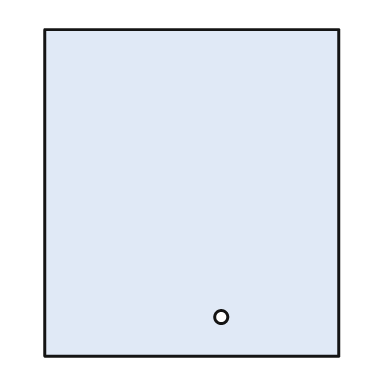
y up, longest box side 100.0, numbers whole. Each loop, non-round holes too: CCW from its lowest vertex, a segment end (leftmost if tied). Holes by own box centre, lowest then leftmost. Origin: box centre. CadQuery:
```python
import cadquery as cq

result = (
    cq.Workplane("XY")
    .moveTo(-45.0, -50.0)
    .lineTo(45.0, -50.0)
    .lineTo(45.0, 50.0)
    .lineTo(-45.0, 50.0)
    .close()
    .moveTo(9.0, -38.0)
    .circle(2.0)
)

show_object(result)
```